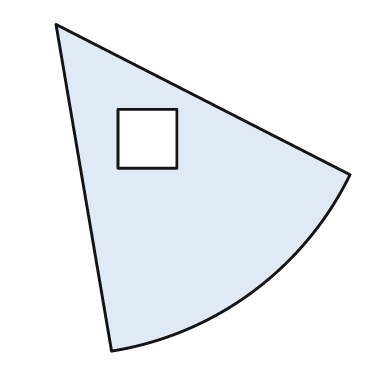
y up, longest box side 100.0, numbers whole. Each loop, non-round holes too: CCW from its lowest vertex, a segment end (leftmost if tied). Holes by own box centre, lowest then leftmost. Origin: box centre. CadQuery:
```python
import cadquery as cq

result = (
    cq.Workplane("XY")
    .moveTo(-28.0, -50.0)
    .threePointArc((15.0, -32.0), (45.0, 4.0))
    .lineTo(-45.0, 50.0)
    .close()
    .moveTo(-26.0, 6.0)
    .lineTo(-8.0, 6.0)
    .lineTo(-8.0, 24.0)
    .lineTo(-26.0, 24.0)
    .close()
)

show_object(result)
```